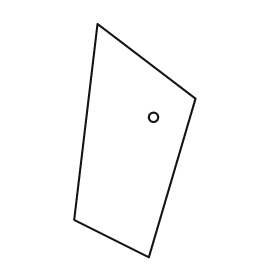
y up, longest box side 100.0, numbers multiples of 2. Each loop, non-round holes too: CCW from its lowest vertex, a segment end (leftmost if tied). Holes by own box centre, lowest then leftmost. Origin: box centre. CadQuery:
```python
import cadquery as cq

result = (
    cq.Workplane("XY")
    .moveTo(6.0, -50.0)
    .lineTo(26.0, 18.0)
    .lineTo(-16.0, 50.0)
    .lineTo(-26.0, -34.0)
    .close()
    .moveTo(8.0, 10.0)
    .circle(2.0)
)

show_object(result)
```